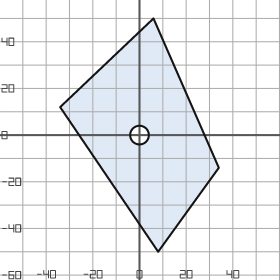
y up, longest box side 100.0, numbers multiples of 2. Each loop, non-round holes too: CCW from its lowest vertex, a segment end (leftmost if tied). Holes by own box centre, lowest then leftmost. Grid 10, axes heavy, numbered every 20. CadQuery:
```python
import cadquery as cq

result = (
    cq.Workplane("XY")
    .moveTo(8.0, -50.0)
    .lineTo(34.0, -14.0)
    .lineTo(6.0, 50.0)
    .lineTo(-34.0, 12.0)
    .close()
    .moveTo(0.0, 0.0)
    .circle(4.0)
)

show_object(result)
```